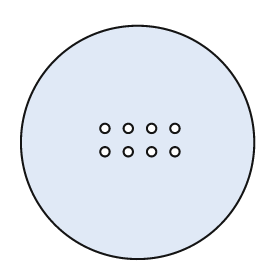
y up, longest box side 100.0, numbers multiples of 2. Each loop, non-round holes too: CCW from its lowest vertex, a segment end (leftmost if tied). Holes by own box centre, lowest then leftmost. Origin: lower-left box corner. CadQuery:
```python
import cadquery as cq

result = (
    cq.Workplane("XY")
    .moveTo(50.0, 50.0)
    .circle(50.0)
    .moveTo(36.0, 46.0)
    .circle(2.0)
    .moveTo(46.0, 46.0)
    .circle(2.0)
    .moveTo(56.0, 46.0)
    .circle(2.0)
    .moveTo(66.0, 46.0)
    .circle(2.0)
    .moveTo(36.0, 56.0)
    .circle(2.0)
    .moveTo(46.0, 56.0)
    .circle(2.0)
    .moveTo(56.0, 56.0)
    .circle(2.0)
    .moveTo(66.0, 56.0)
    .circle(2.0)
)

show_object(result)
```